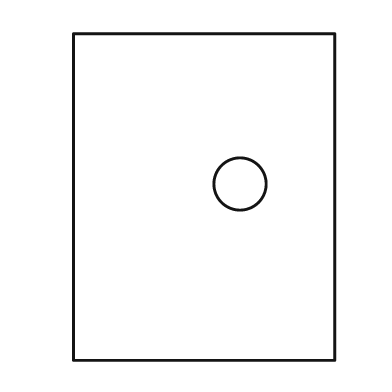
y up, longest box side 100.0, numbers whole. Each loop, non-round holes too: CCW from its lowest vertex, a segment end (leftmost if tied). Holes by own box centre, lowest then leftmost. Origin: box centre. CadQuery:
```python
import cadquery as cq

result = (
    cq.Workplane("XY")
    .moveTo(-40.0, -50.0)
    .lineTo(40.0, -50.0)
    .lineTo(40.0, 50.0)
    .lineTo(-40.0, 50.0)
    .close()
    .moveTo(11.0, 4.0)
    .circle(8.0)
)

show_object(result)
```